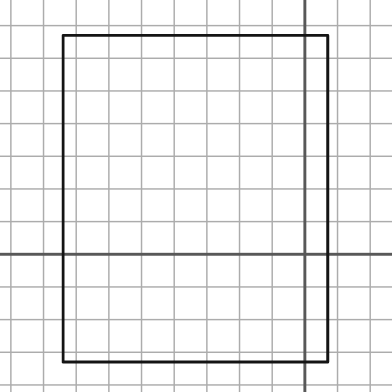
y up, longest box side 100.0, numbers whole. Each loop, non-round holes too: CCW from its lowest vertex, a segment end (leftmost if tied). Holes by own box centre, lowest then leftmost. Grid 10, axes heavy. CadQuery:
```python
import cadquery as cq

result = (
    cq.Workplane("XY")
    .moveTo(-74.0, -33.0)
    .lineTo(7.0, -33.0)
    .lineTo(7.0, 67.0)
    .lineTo(-74.0, 67.0)
    .close()
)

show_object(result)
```